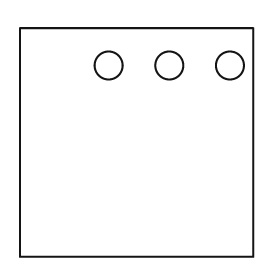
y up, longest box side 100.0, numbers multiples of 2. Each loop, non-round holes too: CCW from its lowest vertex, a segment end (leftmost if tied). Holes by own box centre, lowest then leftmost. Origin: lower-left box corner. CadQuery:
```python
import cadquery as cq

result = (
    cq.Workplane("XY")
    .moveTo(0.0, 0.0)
    .lineTo(100.0, 0.0)
    .lineTo(100.0, 98.0)
    .lineTo(0.0, 98.0)
    .close()
    .moveTo(38.0, 82.0)
    .circle(6.0)
    .moveTo(64.0, 82.0)
    .circle(6.0)
    .moveTo(90.0, 82.0)
    .circle(6.0)
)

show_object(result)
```